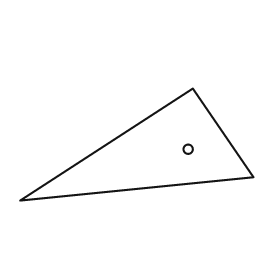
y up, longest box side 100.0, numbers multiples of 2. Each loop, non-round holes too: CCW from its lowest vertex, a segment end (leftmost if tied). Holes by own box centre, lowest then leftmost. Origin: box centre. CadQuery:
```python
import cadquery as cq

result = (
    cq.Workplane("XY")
    .moveTo(-50.0, -24.0)
    .lineTo(50.0, -14.0)
    .lineTo(24.0, 24.0)
    .close()
    .moveTo(22.0, -2.0)
    .circle(2.0)
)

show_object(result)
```